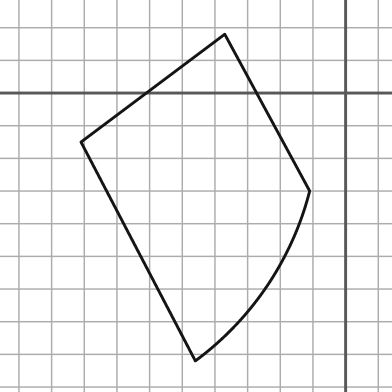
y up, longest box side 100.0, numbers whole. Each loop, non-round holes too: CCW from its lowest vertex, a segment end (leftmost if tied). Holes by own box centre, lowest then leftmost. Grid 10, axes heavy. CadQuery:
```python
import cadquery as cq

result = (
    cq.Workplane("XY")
    .moveTo(-46.0, -82.0)
    .threePointArc((-24.0, -59.0), (-11.0, -30.0))
    .lineTo(-37.0, 18.0)
    .lineTo(-81.0, -15.0)
    .close()
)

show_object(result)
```